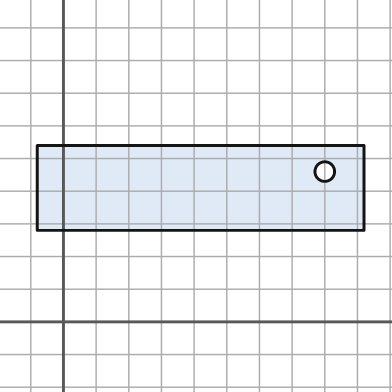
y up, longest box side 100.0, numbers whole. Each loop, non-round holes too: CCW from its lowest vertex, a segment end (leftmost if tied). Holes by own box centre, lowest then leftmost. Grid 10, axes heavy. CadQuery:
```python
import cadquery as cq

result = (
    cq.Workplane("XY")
    .moveTo(-8.0, 28.0)
    .lineTo(92.0, 28.0)
    .lineTo(92.0, 54.0)
    .lineTo(-8.0, 54.0)
    .close()
    .moveTo(80.0, 46.0)
    .circle(3.0)
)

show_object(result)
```